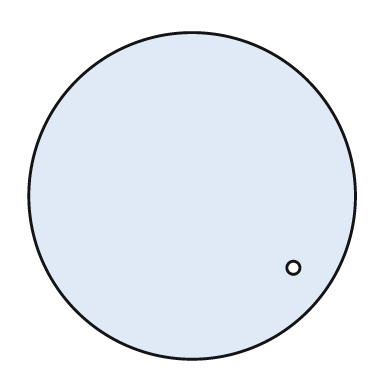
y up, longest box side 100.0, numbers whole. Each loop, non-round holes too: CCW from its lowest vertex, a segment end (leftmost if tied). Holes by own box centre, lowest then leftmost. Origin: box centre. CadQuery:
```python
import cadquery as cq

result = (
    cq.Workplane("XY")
    .moveTo(0.0, 0.0)
    .circle(50.0)
    .moveTo(31.0, -22.0)
    .circle(2.0)
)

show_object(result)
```